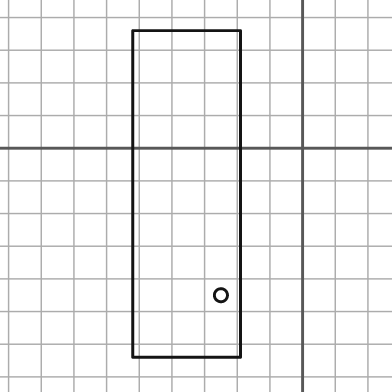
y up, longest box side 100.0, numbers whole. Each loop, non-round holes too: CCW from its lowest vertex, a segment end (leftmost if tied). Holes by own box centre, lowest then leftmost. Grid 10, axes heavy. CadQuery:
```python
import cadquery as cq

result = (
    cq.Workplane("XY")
    .moveTo(-52.0, -64.0)
    .lineTo(-19.0, -64.0)
    .lineTo(-19.0, 36.0)
    .lineTo(-52.0, 36.0)
    .close()
    .moveTo(-25.0, -45.0)
    .circle(2.0)
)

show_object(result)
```